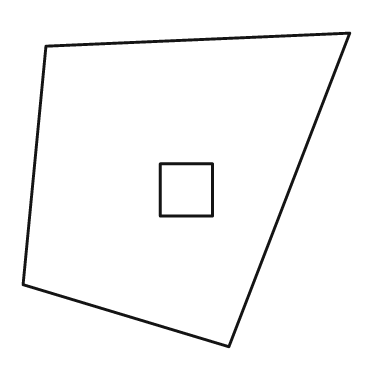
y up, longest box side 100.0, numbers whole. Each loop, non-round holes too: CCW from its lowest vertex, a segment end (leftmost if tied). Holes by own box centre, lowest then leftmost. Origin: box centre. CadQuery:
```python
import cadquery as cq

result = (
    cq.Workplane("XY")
    .moveTo(13.0, -48.0)
    .lineTo(50.0, 48.0)
    .lineTo(-43.0, 44.0)
    .lineTo(-50.0, -29.0)
    .close()
    .moveTo(-8.0, -8.0)
    .lineTo(8.0, -8.0)
    .lineTo(8.0, 8.0)
    .lineTo(-8.0, 8.0)
    .close()
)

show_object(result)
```